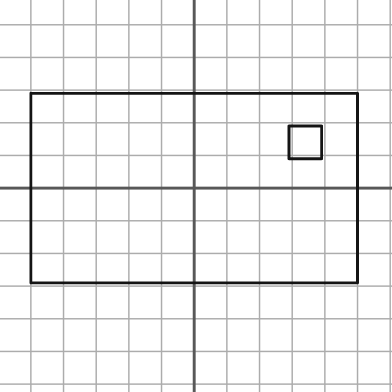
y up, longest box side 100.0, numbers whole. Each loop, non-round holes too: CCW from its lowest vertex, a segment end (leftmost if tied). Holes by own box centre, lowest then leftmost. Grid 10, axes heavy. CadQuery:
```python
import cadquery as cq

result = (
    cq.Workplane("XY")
    .moveTo(-50.0, -29.0)
    .lineTo(50.0, -29.0)
    .lineTo(50.0, 29.0)
    .lineTo(-50.0, 29.0)
    .close()
    .moveTo(29.0, 9.0)
    .lineTo(39.0, 9.0)
    .lineTo(39.0, 19.0)
    .lineTo(29.0, 19.0)
    .close()
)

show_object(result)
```